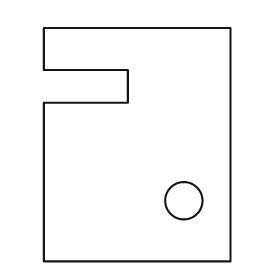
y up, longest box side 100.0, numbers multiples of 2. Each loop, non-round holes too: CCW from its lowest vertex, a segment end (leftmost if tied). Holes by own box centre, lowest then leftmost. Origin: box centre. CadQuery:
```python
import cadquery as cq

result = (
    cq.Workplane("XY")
    .moveTo(-40.0, -50.0)
    .lineTo(40.0, -50.0)
    .lineTo(40.0, 50.0)
    .lineTo(-40.0, 50.0)
    .lineTo(-40.0, 32.0)
    .lineTo(-4.0, 32.0)
    .lineTo(-4.0, 18.0)
    .lineTo(-40.0, 18.0)
    .close()
    .moveTo(20.0, -24.0)
    .circle(8.0)
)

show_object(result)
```